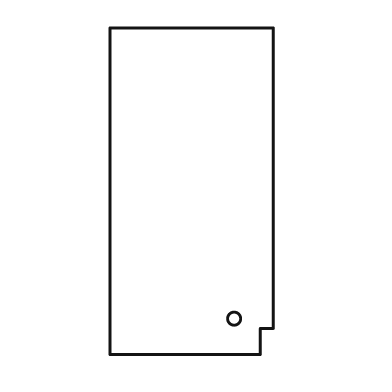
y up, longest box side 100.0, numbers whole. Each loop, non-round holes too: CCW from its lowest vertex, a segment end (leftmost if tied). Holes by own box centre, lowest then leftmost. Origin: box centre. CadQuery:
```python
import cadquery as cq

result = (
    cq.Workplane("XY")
    .moveTo(-25.0, -50.0)
    .lineTo(21.0, -50.0)
    .lineTo(21.0, -42.0)
    .lineTo(25.0, -42.0)
    .lineTo(25.0, 50.0)
    .lineTo(-25.0, 50.0)
    .close()
    .moveTo(13.0, -39.0)
    .circle(2.0)
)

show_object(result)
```